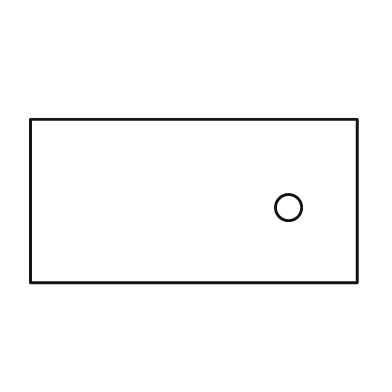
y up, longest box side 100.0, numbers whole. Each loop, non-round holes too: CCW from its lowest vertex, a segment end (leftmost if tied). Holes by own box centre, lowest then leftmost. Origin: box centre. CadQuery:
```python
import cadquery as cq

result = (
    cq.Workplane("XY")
    .moveTo(-50.0, -25.0)
    .lineTo(50.0, -25.0)
    .lineTo(50.0, 25.0)
    .lineTo(-50.0, 25.0)
    .close()
    .moveTo(29.0, -2.0)
    .circle(4.0)
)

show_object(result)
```